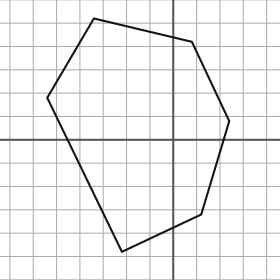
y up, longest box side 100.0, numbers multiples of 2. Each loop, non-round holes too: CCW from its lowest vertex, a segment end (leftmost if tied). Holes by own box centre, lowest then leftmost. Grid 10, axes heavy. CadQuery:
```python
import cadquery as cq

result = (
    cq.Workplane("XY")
    .moveTo(-22.0, -48.0)
    .lineTo(12.0, -32.0)
    .lineTo(24.0, 8.0)
    .lineTo(8.0, 42.0)
    .lineTo(-34.0, 52.0)
    .lineTo(-54.0, 18.0)
    .close()
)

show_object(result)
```